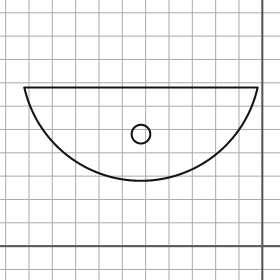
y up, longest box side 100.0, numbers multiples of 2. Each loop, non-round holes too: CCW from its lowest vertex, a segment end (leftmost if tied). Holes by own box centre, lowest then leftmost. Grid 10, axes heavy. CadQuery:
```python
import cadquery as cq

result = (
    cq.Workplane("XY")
    .moveTo(-102.0, 68.0)
    .threePointArc((-52.0, 28.0), (-2.0, 68.0))
    .close()
    .moveTo(-52.0, 48.0)
    .circle(4.0)
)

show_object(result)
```